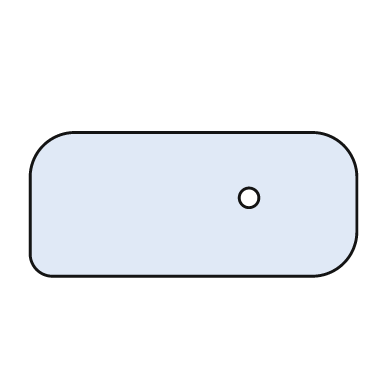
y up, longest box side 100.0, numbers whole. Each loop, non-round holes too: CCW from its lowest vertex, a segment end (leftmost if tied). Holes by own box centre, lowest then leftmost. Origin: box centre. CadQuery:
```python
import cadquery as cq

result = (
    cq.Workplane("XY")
    .moveTo(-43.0, -22.0)
    .lineTo(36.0, -22.0)
    .threePointArc((46.0, -18.0), (50.0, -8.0))
    .lineTo(50.0, 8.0)
    .threePointArc((46.0, 18.0), (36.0, 22.0))
    .lineTo(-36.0, 22.0)
    .threePointArc((-46.0, 18.0), (-50.0, 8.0))
    .lineTo(-50.0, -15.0)
    .threePointArc((-48.0, -20.0), (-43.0, -22.0))
    .close()
    .moveTo(17.0, 2.0)
    .circle(3.0)
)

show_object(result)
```